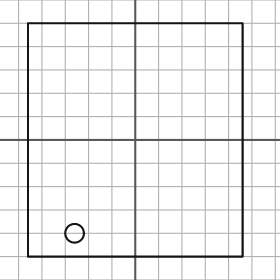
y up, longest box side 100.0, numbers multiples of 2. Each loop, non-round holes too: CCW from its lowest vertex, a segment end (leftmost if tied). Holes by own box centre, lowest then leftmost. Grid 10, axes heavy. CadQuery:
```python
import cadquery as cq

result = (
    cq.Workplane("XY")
    .moveTo(-46.0, -50.0)
    .lineTo(46.0, -50.0)
    .lineTo(46.0, 50.0)
    .lineTo(-46.0, 50.0)
    .close()
    .moveTo(-26.0, -40.0)
    .circle(4.0)
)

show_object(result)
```